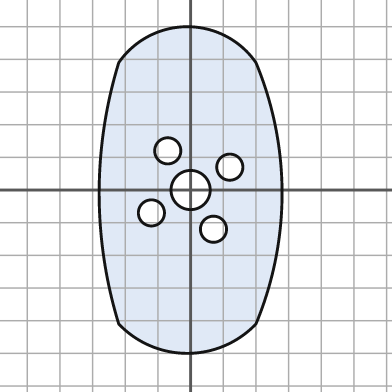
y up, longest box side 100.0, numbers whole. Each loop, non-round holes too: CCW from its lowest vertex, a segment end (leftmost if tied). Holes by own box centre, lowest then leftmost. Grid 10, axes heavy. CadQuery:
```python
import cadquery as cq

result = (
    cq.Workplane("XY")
    .moveTo(-22.0, -41.0)
    .threePointArc((-1.0, -50.0), (20.0, -41.0))
    .threePointArc((28.0, -1.0), (20.0, 39.0))
    .threePointArc((-1.0, 50.0), (-22.0, 39.0))
    .threePointArc((-28.0, -1.0), (-22.0, -41.0))
    .close()
    .moveTo(7.0, -12.0)
    .circle(4.0)
    .moveTo(-12.0, -7.0)
    .circle(4.0)
    .moveTo(0.0, 0.0)
    .circle(6.0)
    .moveTo(12.0, 7.0)
    .circle(4.0)
    .moveTo(-7.0, 12.0)
    .circle(4.0)
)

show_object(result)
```